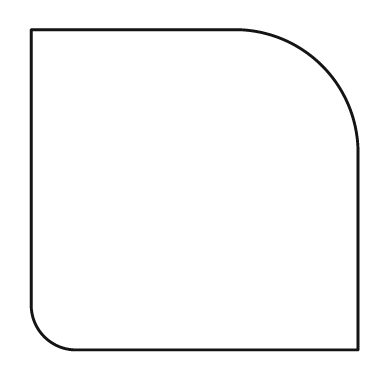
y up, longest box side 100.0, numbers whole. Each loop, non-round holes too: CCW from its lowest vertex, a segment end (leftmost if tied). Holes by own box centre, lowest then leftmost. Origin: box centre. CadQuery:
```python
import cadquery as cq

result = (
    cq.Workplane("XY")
    .moveTo(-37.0, -49.0)
    .lineTo(50.0, -49.0)
    .lineTo(50.0, 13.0)
    .threePointArc((39.0, 38.0), (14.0, 49.0))
    .lineTo(-50.0, 49.0)
    .lineTo(-50.0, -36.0)
    .threePointArc((-46.0, -45.0), (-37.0, -49.0))
    .close()
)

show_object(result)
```